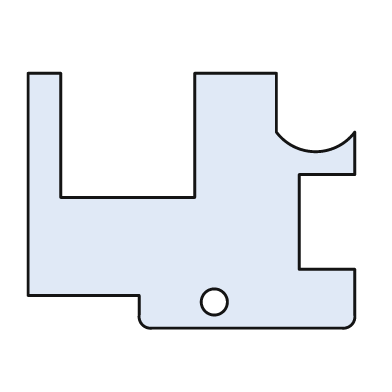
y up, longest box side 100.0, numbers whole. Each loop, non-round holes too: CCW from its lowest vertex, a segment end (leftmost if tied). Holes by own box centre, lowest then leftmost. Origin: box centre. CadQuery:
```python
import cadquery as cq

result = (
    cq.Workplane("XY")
    .moveTo(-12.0, -39.0)
    .lineTo(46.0, -39.0)
    .threePointArc((49.0, -38.0), (50.0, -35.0))
    .lineTo(50.0, -21.0)
    .lineTo(33.0, -21.0)
    .lineTo(33.0, 8.0)
    .lineTo(50.0, 8.0)
    .lineTo(50.0, 21.0)
    .threePointArc((38.0, 15.0), (26.0, 21.0))
    .lineTo(26.0, 39.0)
    .lineTo(1.0, 39.0)
    .lineTo(1.0, 1.0)
    .lineTo(-40.0, 1.0)
    .lineTo(-40.0, 39.0)
    .lineTo(-50.0, 39.0)
    .lineTo(-50.0, -29.0)
    .lineTo(-16.0, -29.0)
    .lineTo(-16.0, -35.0)
    .threePointArc((-15.0, -38.0), (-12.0, -39.0))
    .close()
    .moveTo(7.0, -31.0)
    .circle(4.0)
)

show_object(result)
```